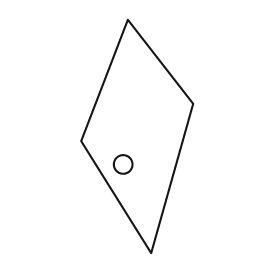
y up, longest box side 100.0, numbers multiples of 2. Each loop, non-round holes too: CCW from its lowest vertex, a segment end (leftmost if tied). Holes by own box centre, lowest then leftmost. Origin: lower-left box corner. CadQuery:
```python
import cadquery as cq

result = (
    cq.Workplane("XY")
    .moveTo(30.0, 0.0)
    .lineTo(48.0, 64.0)
    .lineTo(20.0, 100.0)
    .lineTo(0.0, 48.0)
    .close()
    .moveTo(18.0, 38.0)
    .circle(4.0)
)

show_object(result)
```